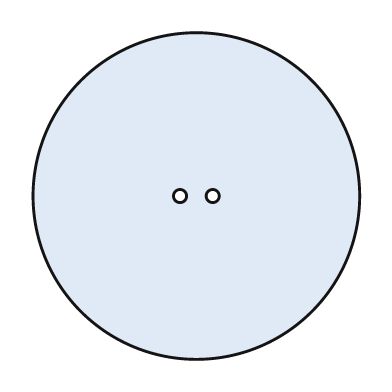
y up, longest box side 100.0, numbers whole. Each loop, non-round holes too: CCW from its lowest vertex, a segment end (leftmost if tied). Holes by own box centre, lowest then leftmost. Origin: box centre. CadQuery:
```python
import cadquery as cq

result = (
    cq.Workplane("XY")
    .moveTo(0.0, 0.0)
    .circle(50.0)
    .moveTo(-5.0, 0.0)
    .circle(2.0)
    .moveTo(5.0, 0.0)
    .circle(2.0)
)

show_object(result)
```